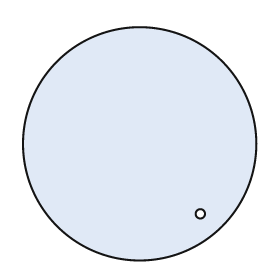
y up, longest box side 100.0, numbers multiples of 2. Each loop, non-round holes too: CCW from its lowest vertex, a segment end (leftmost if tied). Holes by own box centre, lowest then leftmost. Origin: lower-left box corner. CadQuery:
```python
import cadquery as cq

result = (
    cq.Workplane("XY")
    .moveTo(50.0, 50.0)
    .circle(50.0)
    .moveTo(76.0, 20.0)
    .circle(2.0)
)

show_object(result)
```